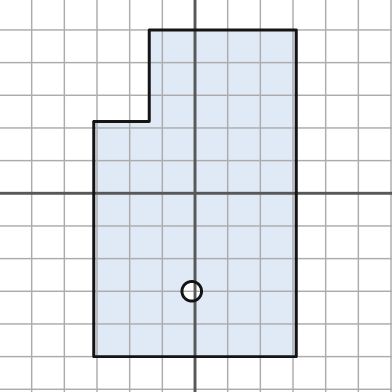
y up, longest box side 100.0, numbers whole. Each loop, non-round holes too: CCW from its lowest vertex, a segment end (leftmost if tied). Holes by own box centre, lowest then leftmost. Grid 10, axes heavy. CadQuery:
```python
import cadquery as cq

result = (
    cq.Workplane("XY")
    .moveTo(-31.0, -50.0)
    .lineTo(31.0, -50.0)
    .lineTo(31.0, 50.0)
    .lineTo(-14.0, 50.0)
    .lineTo(-14.0, 22.0)
    .lineTo(-31.0, 22.0)
    .close()
    .moveTo(-1.0, -30.0)
    .circle(3.0)
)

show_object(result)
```